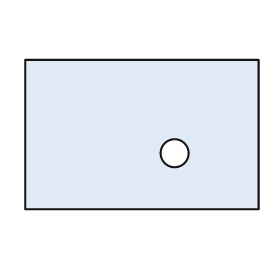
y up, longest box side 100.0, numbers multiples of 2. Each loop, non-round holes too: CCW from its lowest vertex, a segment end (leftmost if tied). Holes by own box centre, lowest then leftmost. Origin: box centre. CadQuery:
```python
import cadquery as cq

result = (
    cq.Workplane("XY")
    .moveTo(-50.0, -32.0)
    .lineTo(50.0, -32.0)
    .lineTo(50.0, 32.0)
    .lineTo(-50.0, 32.0)
    .close()
    .moveTo(14.0, -8.0)
    .circle(6.0)
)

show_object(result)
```